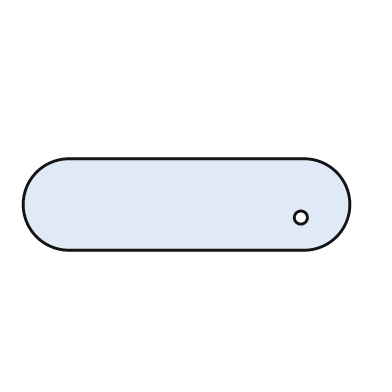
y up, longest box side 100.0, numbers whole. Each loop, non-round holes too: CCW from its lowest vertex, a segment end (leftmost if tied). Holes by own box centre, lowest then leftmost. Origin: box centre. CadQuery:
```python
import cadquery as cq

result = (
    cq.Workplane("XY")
    .moveTo(-36.0, -14.0)
    .lineTo(36.0, -14.0)
    .threePointArc((50.0, 0.0), (36.0, 14.0))
    .lineTo(-36.0, 14.0)
    .threePointArc((-50.0, 0.0), (-36.0, -14.0))
    .close()
    .moveTo(35.0, -4.0)
    .circle(2.0)
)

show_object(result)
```